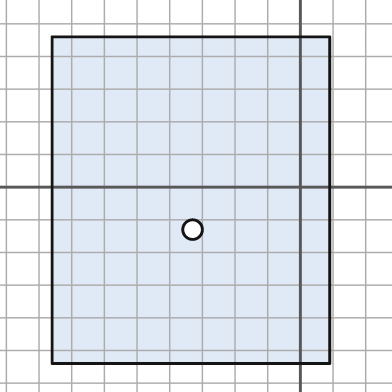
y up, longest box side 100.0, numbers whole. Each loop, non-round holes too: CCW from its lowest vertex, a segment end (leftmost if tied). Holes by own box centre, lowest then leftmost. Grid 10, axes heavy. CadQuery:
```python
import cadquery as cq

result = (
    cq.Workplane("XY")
    .moveTo(-76.0, -54.0)
    .lineTo(9.0, -54.0)
    .lineTo(9.0, 46.0)
    .lineTo(-76.0, 46.0)
    .close()
    .moveTo(-33.0, -13.0)
    .circle(3.0)
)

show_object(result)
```